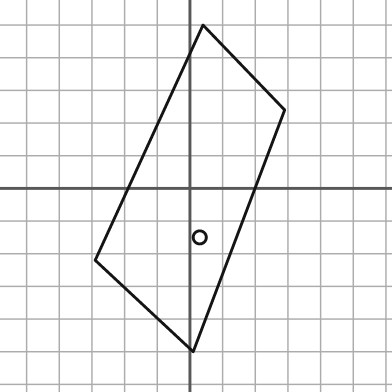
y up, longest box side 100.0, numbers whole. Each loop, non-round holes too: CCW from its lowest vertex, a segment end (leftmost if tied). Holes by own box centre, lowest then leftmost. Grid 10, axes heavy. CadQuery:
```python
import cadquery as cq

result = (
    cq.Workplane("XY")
    .moveTo(1.0, -50.0)
    .lineTo(29.0, 24.0)
    .lineTo(4.0, 50.0)
    .lineTo(-29.0, -22.0)
    .close()
    .moveTo(3.0, -15.0)
    .circle(2.0)
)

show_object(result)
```